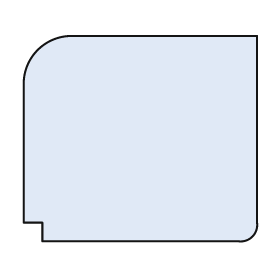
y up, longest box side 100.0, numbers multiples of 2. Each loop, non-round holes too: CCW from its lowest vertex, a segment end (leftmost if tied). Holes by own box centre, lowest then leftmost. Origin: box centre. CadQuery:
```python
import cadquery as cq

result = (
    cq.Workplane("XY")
    .moveTo(-42.0, -44.0)
    .lineTo(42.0, -44.0)
    .threePointArc((48.0, -42.0), (50.0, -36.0))
    .lineTo(50.0, 44.0)
    .lineTo(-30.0, 44.0)
    .threePointArc((-44.0, 38.0), (-50.0, 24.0))
    .lineTo(-50.0, -36.0)
    .lineTo(-42.0, -36.0)
    .close()
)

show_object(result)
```